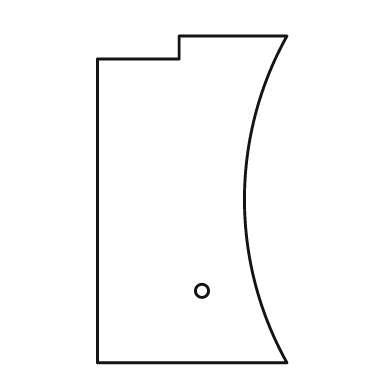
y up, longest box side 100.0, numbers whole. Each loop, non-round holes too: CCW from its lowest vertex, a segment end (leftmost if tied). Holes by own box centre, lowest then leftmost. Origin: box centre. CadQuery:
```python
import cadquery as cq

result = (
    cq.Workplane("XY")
    .moveTo(-29.0, -50.0)
    .lineTo(29.0, -50.0)
    .threePointArc((16.0, 0.0), (29.0, 50.0))
    .lineTo(-4.0, 50.0)
    .lineTo(-4.0, 43.0)
    .lineTo(-29.0, 43.0)
    .close()
    .moveTo(3.0, -28.0)
    .circle(2.0)
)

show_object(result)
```